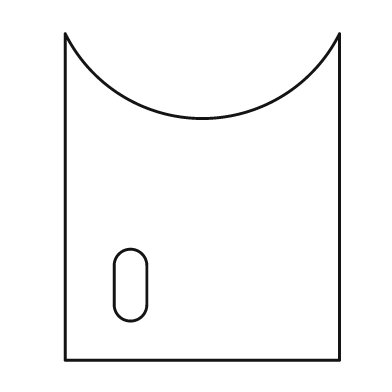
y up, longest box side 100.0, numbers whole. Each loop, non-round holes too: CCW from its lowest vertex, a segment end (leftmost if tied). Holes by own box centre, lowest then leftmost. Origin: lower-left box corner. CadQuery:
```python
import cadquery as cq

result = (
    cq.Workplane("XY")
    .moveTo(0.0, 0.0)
    .lineTo(84.0, 0.0)
    .lineTo(84.0, 100.0)
    .threePointArc((42.0, 74.0), (0.0, 100.0))
    .close()
    .moveTo(15.0, 17.0)
    .threePointArc((20.0, 12.0), (25.0, 17.0))
    .lineTo(25.0, 29.0)
    .threePointArc((20.0, 34.0), (15.0, 29.0))
    .close()
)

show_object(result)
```